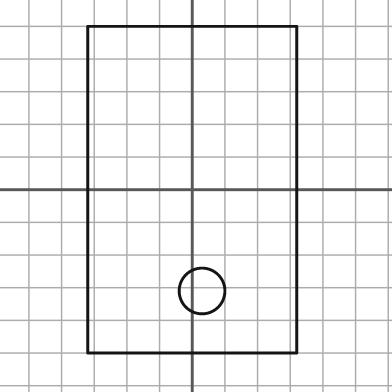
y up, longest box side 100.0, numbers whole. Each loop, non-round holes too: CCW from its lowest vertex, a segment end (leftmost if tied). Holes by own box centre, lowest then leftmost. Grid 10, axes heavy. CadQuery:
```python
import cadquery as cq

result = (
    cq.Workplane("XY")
    .moveTo(-32.0, -50.0)
    .lineTo(32.0, -50.0)
    .lineTo(32.0, 50.0)
    .lineTo(-32.0, 50.0)
    .close()
    .moveTo(3.0, -31.0)
    .circle(7.0)
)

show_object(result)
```